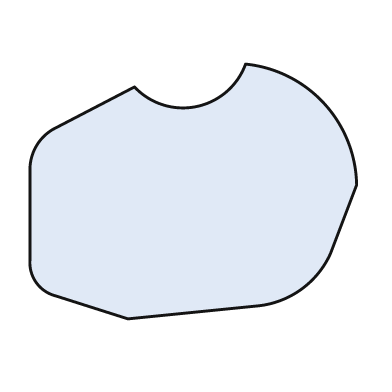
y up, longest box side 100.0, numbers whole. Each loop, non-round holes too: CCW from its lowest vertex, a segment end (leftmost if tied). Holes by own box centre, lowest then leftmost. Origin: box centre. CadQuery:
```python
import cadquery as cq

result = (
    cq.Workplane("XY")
    .moveTo(-20.0, -39.0)
    .lineTo(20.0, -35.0)
    .threePointArc((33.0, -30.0), (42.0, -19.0))
    .lineTo(50.0, 2.0)
    .threePointArc((40.0, 27.0), (16.0, 39.0))
    .threePointArc((1.0, 26.0), (-18.0, 32.0))
    .lineTo(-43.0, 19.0)
    .threePointArc((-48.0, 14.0), (-50.0, 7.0))
    .lineTo(-50.0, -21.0)
    .threePointArc((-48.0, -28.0), (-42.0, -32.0))
    .close()
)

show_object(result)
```